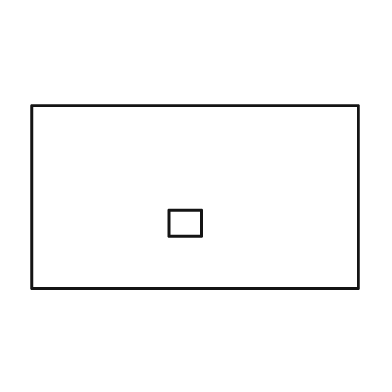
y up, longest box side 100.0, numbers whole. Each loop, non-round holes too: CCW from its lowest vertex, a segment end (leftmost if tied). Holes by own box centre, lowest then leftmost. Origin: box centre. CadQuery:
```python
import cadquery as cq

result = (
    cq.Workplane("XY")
    .moveTo(-50.0, -28.0)
    .lineTo(50.0, -28.0)
    .lineTo(50.0, 28.0)
    .lineTo(-50.0, 28.0)
    .close()
    .moveTo(-8.0, -12.0)
    .lineTo(2.0, -12.0)
    .lineTo(2.0, -4.0)
    .lineTo(-8.0, -4.0)
    .close()
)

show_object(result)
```